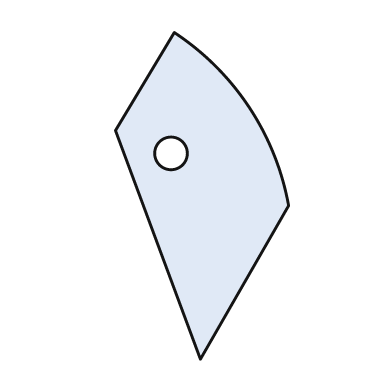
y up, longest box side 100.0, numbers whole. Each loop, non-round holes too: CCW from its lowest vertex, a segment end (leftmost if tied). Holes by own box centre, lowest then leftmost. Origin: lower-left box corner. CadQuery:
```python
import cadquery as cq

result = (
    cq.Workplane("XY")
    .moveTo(26.0, 0.0)
    .lineTo(53.0, 47.0)
    .threePointArc((41.0, 77.0), (18.0, 100.0))
    .lineTo(0.0, 70.0)
    .close()
    .moveTo(17.0, 63.0)
    .circle(5.0)
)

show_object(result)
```